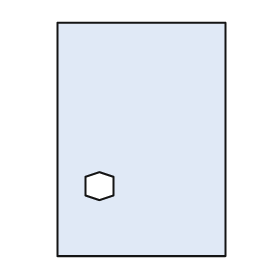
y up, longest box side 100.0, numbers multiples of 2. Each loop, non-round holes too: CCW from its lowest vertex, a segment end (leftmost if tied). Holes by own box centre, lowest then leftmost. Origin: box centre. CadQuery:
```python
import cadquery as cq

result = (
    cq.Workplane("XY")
    .moveTo(-36.0, -50.0)
    .lineTo(36.0, -50.0)
    .lineTo(36.0, 50.0)
    .lineTo(-36.0, 50.0)
    .close()
    .moveTo(-18.0, -26.0)
    .lineTo(-12.0, -24.0)
    .lineTo(-12.0, -16.0)
    .lineTo(-18.0, -14.0)
    .lineTo(-24.0, -16.0)
    .lineTo(-24.0, -24.0)
    .close()
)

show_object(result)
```